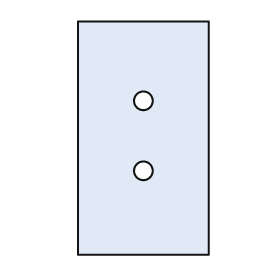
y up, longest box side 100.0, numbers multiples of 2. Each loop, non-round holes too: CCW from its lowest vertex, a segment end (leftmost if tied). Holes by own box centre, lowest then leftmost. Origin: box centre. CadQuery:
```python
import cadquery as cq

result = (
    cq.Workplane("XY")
    .moveTo(-28.0, -50.0)
    .lineTo(28.0, -50.0)
    .lineTo(28.0, 50.0)
    .lineTo(-28.0, 50.0)
    .close()
    .moveTo(0.0, -14.0)
    .circle(4.0)
    .moveTo(0.0, 16.0)
    .circle(4.0)
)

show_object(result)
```